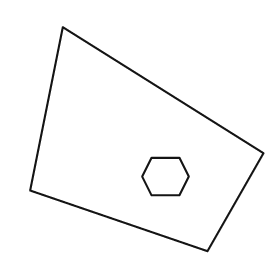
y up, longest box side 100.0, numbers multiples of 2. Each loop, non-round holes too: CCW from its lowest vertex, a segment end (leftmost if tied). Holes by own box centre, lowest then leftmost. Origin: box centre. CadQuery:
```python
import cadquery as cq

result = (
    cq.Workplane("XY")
    .moveTo(26.0, -48.0)
    .lineTo(50.0, -6.0)
    .lineTo(-36.0, 48.0)
    .lineTo(-50.0, -22.0)
    .close()
    .moveTo(2.0, -24.0)
    .lineTo(14.0, -24.0)
    .lineTo(18.0, -16.0)
    .lineTo(14.0, -8.0)
    .lineTo(2.0, -8.0)
    .lineTo(-2.0, -16.0)
    .close()
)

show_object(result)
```